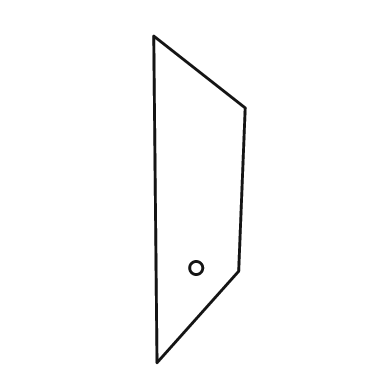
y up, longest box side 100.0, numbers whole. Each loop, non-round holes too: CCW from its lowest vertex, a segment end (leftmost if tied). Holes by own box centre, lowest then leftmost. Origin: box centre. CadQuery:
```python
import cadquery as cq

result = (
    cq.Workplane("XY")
    .moveTo(-13.0, -50.0)
    .lineTo(12.0, -22.0)
    .lineTo(14.0, 28.0)
    .lineTo(-14.0, 50.0)
    .close()
    .moveTo(-1.0, -21.0)
    .circle(2.0)
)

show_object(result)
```